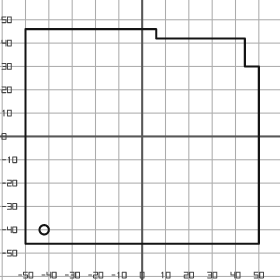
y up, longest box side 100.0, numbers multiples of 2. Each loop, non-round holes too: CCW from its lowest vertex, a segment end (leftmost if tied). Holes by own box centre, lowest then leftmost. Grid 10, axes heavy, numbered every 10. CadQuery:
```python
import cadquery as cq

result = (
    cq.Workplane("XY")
    .moveTo(-50.0, -46.0)
    .lineTo(50.0, -46.0)
    .lineTo(50.0, 30.0)
    .lineTo(44.0, 30.0)
    .lineTo(44.0, 42.0)
    .lineTo(6.0, 42.0)
    .lineTo(6.0, 46.0)
    .lineTo(-50.0, 46.0)
    .close()
    .moveTo(-42.0, -40.0)
    .circle(2.0)
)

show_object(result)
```